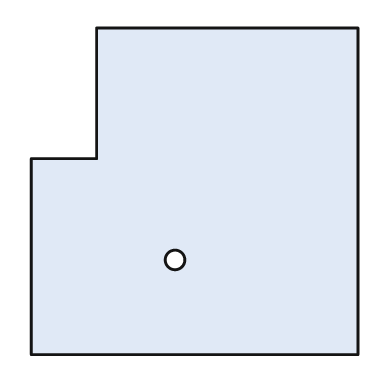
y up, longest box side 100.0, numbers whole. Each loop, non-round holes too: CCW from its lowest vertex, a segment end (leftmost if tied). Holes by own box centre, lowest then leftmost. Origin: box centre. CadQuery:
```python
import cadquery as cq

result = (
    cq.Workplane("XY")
    .moveTo(-50.0, -50.0)
    .lineTo(50.0, -50.0)
    .lineTo(50.0, 50.0)
    .lineTo(-30.0, 50.0)
    .lineTo(-30.0, 10.0)
    .lineTo(-50.0, 10.0)
    .close()
    .moveTo(-6.0, -21.0)
    .circle(3.0)
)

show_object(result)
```